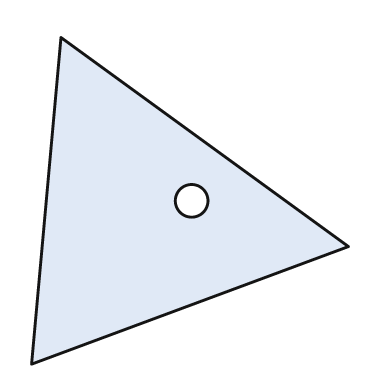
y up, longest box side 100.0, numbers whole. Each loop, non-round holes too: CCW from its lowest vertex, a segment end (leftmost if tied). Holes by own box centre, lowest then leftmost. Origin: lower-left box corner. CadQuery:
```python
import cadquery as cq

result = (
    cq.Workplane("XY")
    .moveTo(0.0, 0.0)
    .lineTo(97.0, 36.0)
    .lineTo(9.0, 100.0)
    .close()
    .moveTo(49.0, 50.0)
    .circle(5.0)
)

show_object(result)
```